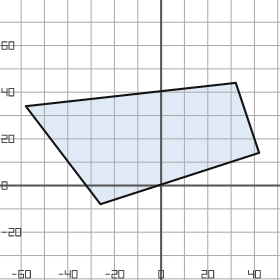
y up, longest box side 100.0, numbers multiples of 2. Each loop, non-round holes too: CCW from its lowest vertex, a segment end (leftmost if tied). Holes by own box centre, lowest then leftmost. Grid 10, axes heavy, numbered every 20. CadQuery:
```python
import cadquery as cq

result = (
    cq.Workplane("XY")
    .moveTo(-26.0, -8.0)
    .lineTo(42.0, 14.0)
    .lineTo(32.0, 44.0)
    .lineTo(-58.0, 34.0)
    .close()
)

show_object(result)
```